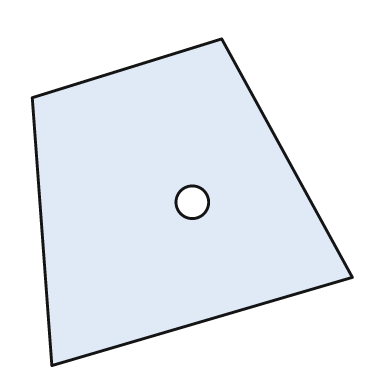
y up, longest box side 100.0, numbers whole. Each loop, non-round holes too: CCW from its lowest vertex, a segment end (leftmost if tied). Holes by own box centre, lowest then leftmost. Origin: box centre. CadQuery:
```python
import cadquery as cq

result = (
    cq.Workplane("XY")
    .moveTo(-43.0, -50.0)
    .lineTo(49.0, -23.0)
    .lineTo(9.0, 50.0)
    .lineTo(-49.0, 32.0)
    .close()
    .moveTo(0.0, 0.0)
    .circle(5.0)
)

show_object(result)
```